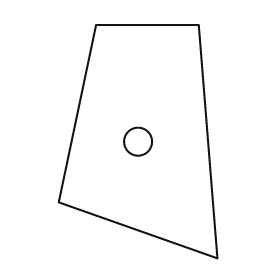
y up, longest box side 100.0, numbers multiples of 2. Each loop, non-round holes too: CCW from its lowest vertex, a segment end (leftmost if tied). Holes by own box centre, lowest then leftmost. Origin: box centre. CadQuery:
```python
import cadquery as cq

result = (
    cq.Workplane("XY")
    .moveTo(34.0, -50.0)
    .lineTo(26.0, 50.0)
    .lineTo(-18.0, 50.0)
    .lineTo(-34.0, -26.0)
    .close()
    .moveTo(0.0, 0.0)
    .circle(6.0)
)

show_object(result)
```